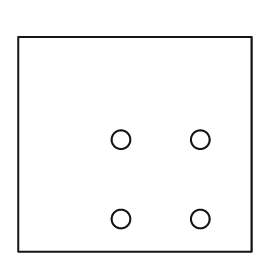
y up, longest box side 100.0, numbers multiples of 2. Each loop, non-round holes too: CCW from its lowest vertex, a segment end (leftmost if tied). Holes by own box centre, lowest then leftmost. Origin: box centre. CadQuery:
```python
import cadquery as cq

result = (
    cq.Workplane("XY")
    .moveTo(-50.0, -46.0)
    .lineTo(50.0, -46.0)
    .lineTo(50.0, 46.0)
    .lineTo(-50.0, 46.0)
    .close()
    .moveTo(-6.0, -32.0)
    .circle(4.0)
    .moveTo(28.0, -32.0)
    .circle(4.0)
    .moveTo(-6.0, 2.0)
    .circle(4.0)
    .moveTo(28.0, 2.0)
    .circle(4.0)
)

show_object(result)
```